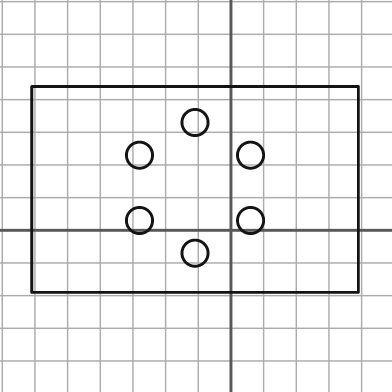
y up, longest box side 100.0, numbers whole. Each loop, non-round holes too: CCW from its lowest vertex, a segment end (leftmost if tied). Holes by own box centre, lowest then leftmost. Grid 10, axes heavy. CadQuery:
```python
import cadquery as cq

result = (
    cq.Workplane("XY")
    .moveTo(-61.0, -19.0)
    .lineTo(39.0, -19.0)
    .lineTo(39.0, 44.0)
    .lineTo(-61.0, 44.0)
    .close()
    .moveTo(-11.0, -7.0)
    .circle(4.0)
    .moveTo(-28.0, 3.0)
    .circle(4.0)
    .moveTo(6.0, 3.0)
    .circle(4.0)
    .moveTo(-28.0, 23.0)
    .circle(4.0)
    .moveTo(6.0, 23.0)
    .circle(4.0)
    .moveTo(-11.0, 33.0)
    .circle(4.0)
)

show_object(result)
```